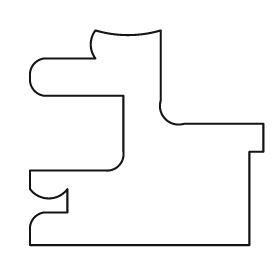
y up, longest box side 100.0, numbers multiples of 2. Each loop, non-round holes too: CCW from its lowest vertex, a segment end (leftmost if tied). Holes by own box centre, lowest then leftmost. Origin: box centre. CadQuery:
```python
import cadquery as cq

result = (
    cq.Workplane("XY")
    .moveTo(-50.0, -46.0)
    .lineTo(44.0, -46.0)
    .lineTo(44.0, -6.0)
    .lineTo(50.0, -6.0)
    .lineTo(50.0, 6.0)
    .lineTo(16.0, 6.0)
    .threePointArc((8.0, 8.0), (6.0, 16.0))
    .lineTo(6.0, 46.0)
    .threePointArc((-8.0, 44.0), (-22.0, 46.0))
    .threePointArc((-24.0, 40.0), (-22.0, 34.0))
    .lineTo(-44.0, 34.0)
    .threePointArc((-48.0, 32.0), (-50.0, 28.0))
    .lineTo(-50.0, 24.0)
    .threePointArc((-48.0, 20.0), (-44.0, 18.0))
    .lineTo(-10.0, 18.0)
    .lineTo(-10.0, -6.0)
    .threePointArc((-12.0, -12.0), (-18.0, -14.0))
    .lineTo(-50.0, -14.0)
    .lineTo(-50.0, -22.0)
    .threePointArc((-42.0, -26.0), (-34.0, -22.0))
    .lineTo(-34.0, -32.0)
    .lineTo(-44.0, -32.0)
    .threePointArc((-48.0, -34.0), (-50.0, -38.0))
    .close()
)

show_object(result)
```